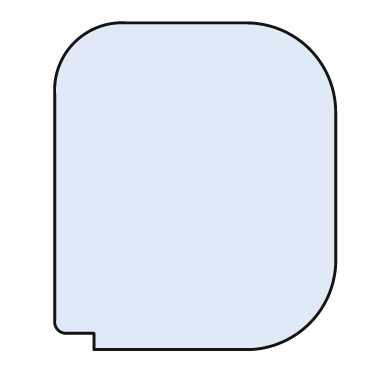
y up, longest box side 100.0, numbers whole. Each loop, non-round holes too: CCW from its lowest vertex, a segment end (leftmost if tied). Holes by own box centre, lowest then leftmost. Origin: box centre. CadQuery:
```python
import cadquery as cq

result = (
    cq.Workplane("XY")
    .moveTo(-31.0, -50.0)
    .lineTo(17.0, -50.0)
    .threePointArc((35.0, -42.0), (43.0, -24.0))
    .lineTo(43.0, 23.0)
    .threePointArc((35.0, 42.0), (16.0, 50.0))
    .lineTo(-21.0, 50.0)
    .threePointArc((-37.0, 44.0), (-43.0, 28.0))
    .lineTo(-43.0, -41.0)
    .threePointArc((-42.0, -44.0), (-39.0, -45.0))
    .lineTo(-31.0, -45.0)
    .close()
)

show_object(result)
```